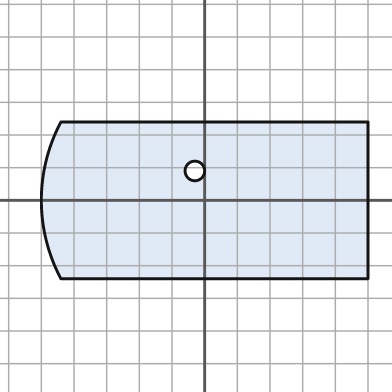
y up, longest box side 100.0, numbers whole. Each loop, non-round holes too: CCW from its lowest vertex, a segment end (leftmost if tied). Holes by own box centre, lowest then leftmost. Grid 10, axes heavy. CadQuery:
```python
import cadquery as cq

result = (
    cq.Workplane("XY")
    .moveTo(-44.0, -24.0)
    .lineTo(50.0, -24.0)
    .lineTo(50.0, 24.0)
    .lineTo(-44.0, 24.0)
    .threePointArc((-50.0, 0.0), (-44.0, -24.0))
    .close()
    .moveTo(-3.0, 9.0)
    .circle(3.0)
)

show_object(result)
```